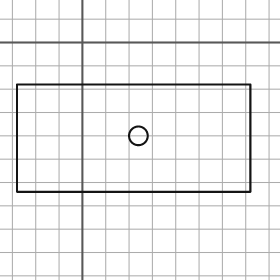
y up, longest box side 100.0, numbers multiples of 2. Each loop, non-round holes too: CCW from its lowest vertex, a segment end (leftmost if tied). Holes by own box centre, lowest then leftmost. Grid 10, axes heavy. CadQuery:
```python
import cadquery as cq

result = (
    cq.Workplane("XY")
    .moveTo(-28.0, -64.0)
    .lineTo(72.0, -64.0)
    .lineTo(72.0, -18.0)
    .lineTo(-28.0, -18.0)
    .close()
    .moveTo(24.0, -40.0)
    .circle(4.0)
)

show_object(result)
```